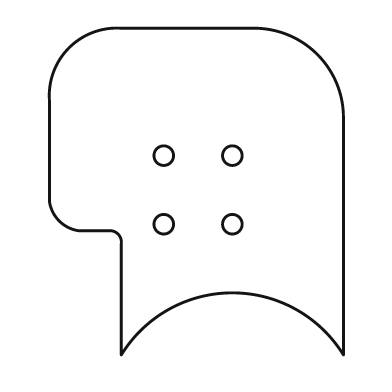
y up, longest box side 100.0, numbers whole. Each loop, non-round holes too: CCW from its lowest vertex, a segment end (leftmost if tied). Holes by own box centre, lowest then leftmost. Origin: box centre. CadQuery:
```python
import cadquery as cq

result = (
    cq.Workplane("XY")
    .moveTo(-23.0, -50.0)
    .threePointArc((11.0, -31.0), (45.0, -50.0))
    .lineTo(45.0, 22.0)
    .threePointArc((37.0, 42.0), (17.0, 50.0))
    .lineTo(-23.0, 50.0)
    .threePointArc((-39.0, 44.0), (-45.0, 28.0))
    .lineTo(-45.0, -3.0)
    .threePointArc((-42.0, -9.0), (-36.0, -12.0))
    .lineTo(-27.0, -12.0)
    .threePointArc((-24.0, -13.0), (-23.0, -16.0))
    .close()
    .moveTo(-10.0, -10.0)
    .circle(3.0)
    .moveTo(11.0, -10.0)
    .circle(3.0)
    .moveTo(-10.0, 11.0)
    .circle(3.0)
    .moveTo(11.0, 11.0)
    .circle(3.0)
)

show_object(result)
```